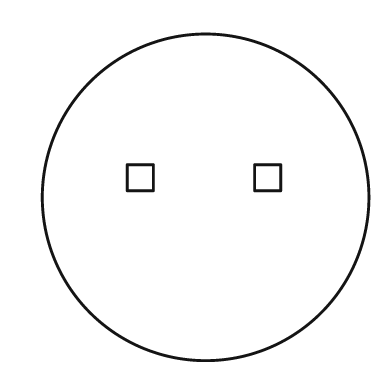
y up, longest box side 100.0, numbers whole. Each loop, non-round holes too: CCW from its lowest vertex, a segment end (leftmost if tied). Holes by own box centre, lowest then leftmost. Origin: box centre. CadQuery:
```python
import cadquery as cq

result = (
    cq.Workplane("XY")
    .moveTo(0.0, 0.0)
    .circle(50.0)
    .moveTo(-24.0, 2.0)
    .lineTo(-16.0, 2.0)
    .lineTo(-16.0, 10.0)
    .lineTo(-24.0, 10.0)
    .close()
    .moveTo(15.0, 2.0)
    .lineTo(23.0, 2.0)
    .lineTo(23.0, 10.0)
    .lineTo(15.0, 10.0)
    .close()
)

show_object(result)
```